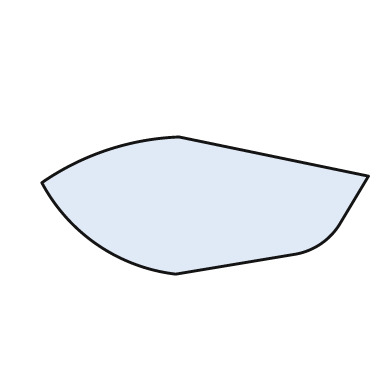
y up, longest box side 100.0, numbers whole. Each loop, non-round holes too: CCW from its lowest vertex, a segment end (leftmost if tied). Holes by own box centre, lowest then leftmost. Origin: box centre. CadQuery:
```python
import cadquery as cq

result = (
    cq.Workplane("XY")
    .moveTo(-9.0, -21.0)
    .lineTo(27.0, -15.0)
    .threePointArc((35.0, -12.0), (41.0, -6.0))
    .lineTo(50.0, 9.0)
    .lineTo(-8.0, 21.0)
    .threePointArc((-30.0, 17.0), (-50.0, 7.0))
    .threePointArc((-33.0, -12.0), (-9.0, -21.0))
    .close()
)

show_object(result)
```